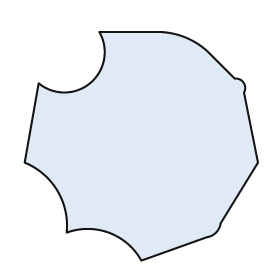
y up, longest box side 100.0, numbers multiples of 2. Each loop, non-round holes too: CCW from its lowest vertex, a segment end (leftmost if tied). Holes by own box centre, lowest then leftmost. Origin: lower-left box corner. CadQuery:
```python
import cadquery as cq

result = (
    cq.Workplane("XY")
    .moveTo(50.0, 0.0)
    .lineTo(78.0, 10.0)
    .threePointArc((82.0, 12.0), (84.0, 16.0))
    .lineTo(100.0, 42.0)
    .lineTo(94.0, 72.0)
    .threePointArc((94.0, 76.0), (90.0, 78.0))
    .lineTo(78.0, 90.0)
    .threePointArc((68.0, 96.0), (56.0, 98.0))
    .lineTo(32.0, 98.0)
    .threePointArc((28.0, 76.0), (6.0, 76.0))
    .lineTo(0.0, 42.0)
    .threePointArc((14.0, 30.0), (18.0, 12.0))
    .threePointArc((36.0, 12.0), (50.0, 0.0))
    .close()
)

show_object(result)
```